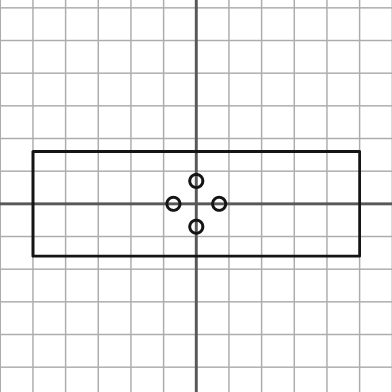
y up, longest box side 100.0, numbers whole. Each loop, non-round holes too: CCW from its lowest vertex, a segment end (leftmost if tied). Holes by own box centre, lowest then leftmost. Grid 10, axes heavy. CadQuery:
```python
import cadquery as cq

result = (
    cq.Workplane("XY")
    .moveTo(-50.0, -16.0)
    .lineTo(50.0, -16.0)
    .lineTo(50.0, 16.0)
    .lineTo(-50.0, 16.0)
    .close()
    .moveTo(0.0, -7.0)
    .circle(2.0)
    .moveTo(-7.0, 0.0)
    .circle(2.0)
    .moveTo(7.0, 0.0)
    .circle(2.0)
    .moveTo(0.0, 7.0)
    .circle(2.0)
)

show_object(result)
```